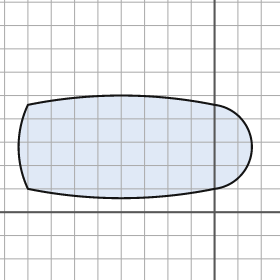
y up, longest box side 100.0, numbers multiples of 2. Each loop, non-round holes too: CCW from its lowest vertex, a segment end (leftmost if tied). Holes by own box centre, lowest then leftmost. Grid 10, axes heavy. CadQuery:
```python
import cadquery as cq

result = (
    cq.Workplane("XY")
    .moveTo(-80.0, 10.0)
    .threePointArc((-40.0, 6.0), (0.0, 10.0))
    .threePointArc((16.0, 28.0), (0.0, 46.0))
    .threePointArc((-40.0, 50.0), (-80.0, 46.0))
    .threePointArc((-84.0, 28.0), (-80.0, 10.0))
    .close()
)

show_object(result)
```